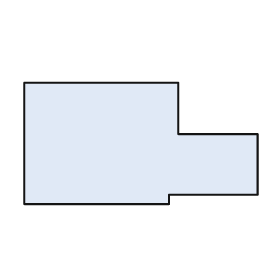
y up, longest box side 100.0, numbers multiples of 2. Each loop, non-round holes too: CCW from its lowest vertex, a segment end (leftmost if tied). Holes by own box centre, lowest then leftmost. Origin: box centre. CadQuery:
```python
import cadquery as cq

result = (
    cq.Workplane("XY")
    .moveTo(-50.0, -26.0)
    .lineTo(12.0, -26.0)
    .lineTo(12.0, -22.0)
    .lineTo(50.0, -22.0)
    .lineTo(50.0, 4.0)
    .lineTo(16.0, 4.0)
    .lineTo(16.0, 26.0)
    .lineTo(-50.0, 26.0)
    .close()
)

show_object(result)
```